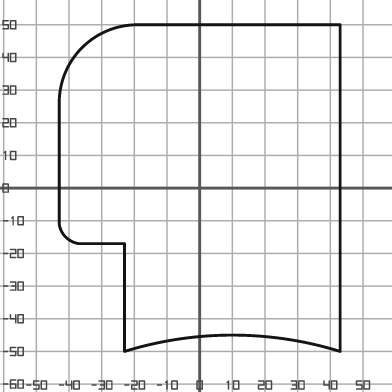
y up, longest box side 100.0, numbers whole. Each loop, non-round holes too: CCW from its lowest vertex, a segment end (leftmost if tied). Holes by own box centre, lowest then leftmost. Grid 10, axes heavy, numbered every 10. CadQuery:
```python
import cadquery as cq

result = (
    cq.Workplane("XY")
    .moveTo(-23.0, -50.0)
    .threePointArc((10.0, -45.0), (43.0, -50.0))
    .lineTo(43.0, 50.0)
    .lineTo(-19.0, 50.0)
    .threePointArc((-36.0, 43.0), (-43.0, 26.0))
    .lineTo(-43.0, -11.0)
    .threePointArc((-41.0, -15.0), (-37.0, -17.0))
    .lineTo(-23.0, -17.0)
    .close()
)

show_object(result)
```